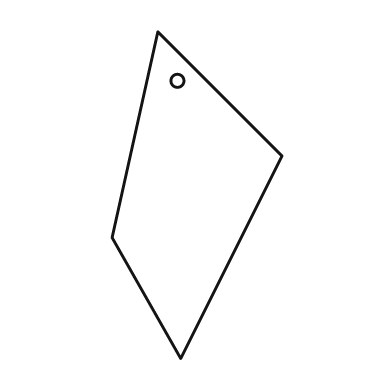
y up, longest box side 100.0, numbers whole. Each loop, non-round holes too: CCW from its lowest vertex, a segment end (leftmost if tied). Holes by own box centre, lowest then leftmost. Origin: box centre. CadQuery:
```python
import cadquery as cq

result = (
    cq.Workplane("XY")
    .moveTo(-5.0, -50.0)
    .lineTo(26.0, 12.0)
    .lineTo(-12.0, 50.0)
    .lineTo(-26.0, -13.0)
    .close()
    .moveTo(-6.0, 35.0)
    .circle(2.0)
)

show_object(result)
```